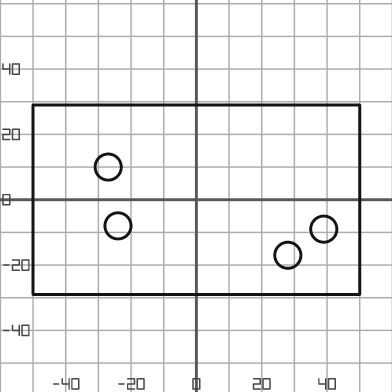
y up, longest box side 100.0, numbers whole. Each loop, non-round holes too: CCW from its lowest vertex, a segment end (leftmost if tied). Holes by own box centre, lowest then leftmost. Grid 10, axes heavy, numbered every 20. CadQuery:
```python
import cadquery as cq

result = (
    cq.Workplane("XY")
    .moveTo(-50.0, -29.0)
    .lineTo(50.0, -29.0)
    .lineTo(50.0, 29.0)
    .lineTo(-50.0, 29.0)
    .close()
    .moveTo(28.0, -17.0)
    .circle(4.0)
    .moveTo(39.0, -9.0)
    .circle(4.0)
    .moveTo(-24.0, -8.0)
    .circle(4.0)
    .moveTo(-27.0, 10.0)
    .circle(4.0)
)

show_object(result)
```